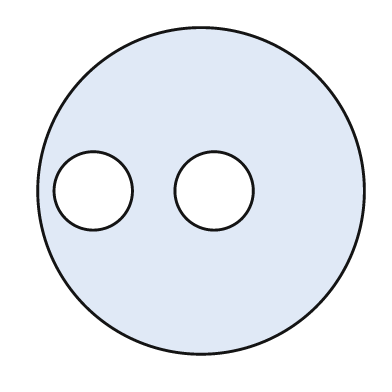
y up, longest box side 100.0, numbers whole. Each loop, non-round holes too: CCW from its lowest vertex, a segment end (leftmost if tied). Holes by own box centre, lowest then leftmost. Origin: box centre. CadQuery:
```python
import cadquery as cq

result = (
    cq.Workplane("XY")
    .moveTo(0.0, 0.0)
    .circle(50.0)
    .moveTo(-33.0, 0.0)
    .circle(12.0)
    .moveTo(4.0, 0.0)
    .circle(12.0)
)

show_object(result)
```